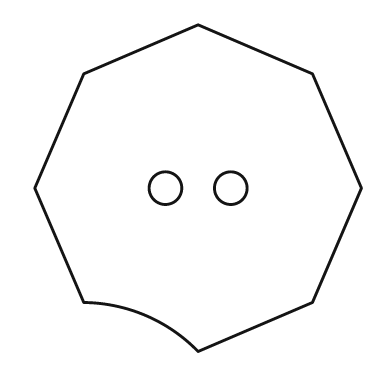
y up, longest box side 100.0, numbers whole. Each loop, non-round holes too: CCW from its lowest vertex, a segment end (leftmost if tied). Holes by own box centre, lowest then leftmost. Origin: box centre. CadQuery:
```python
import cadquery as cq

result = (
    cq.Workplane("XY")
    .moveTo(0.0, -50.0)
    .lineTo(35.0, -35.0)
    .lineTo(50.0, 0.0)
    .lineTo(35.0, 35.0)
    .lineTo(0.0, 50.0)
    .lineTo(-35.0, 35.0)
    .lineTo(-50.0, 0.0)
    .lineTo(-35.0, -35.0)
    .threePointArc((-16.0, -39.0), (0.0, -50.0))
    .close()
    .moveTo(-10.0, 0.0)
    .circle(5.0)
    .moveTo(10.0, 0.0)
    .circle(5.0)
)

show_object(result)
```